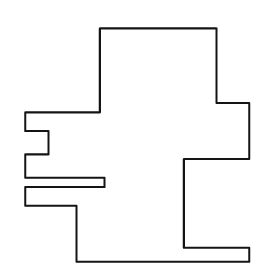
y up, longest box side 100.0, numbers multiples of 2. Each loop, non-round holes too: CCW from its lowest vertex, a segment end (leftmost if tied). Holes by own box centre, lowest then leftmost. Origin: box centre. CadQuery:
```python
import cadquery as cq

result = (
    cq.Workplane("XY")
    .moveTo(-26.0, -50.0)
    .lineTo(48.0, -50.0)
    .lineTo(48.0, -44.0)
    .lineTo(20.0, -44.0)
    .lineTo(20.0, -6.0)
    .lineTo(48.0, -6.0)
    .lineTo(48.0, 18.0)
    .lineTo(34.0, 18.0)
    .lineTo(34.0, 50.0)
    .lineTo(-16.0, 50.0)
    .lineTo(-16.0, 14.0)
    .lineTo(-48.0, 14.0)
    .lineTo(-48.0, 6.0)
    .lineTo(-38.0, 6.0)
    .lineTo(-38.0, -4.0)
    .lineTo(-48.0, -4.0)
    .lineTo(-48.0, -14.0)
    .lineTo(-14.0, -14.0)
    .lineTo(-14.0, -18.0)
    .lineTo(-48.0, -18.0)
    .lineTo(-48.0, -26.0)
    .lineTo(-26.0, -26.0)
    .close()
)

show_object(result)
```